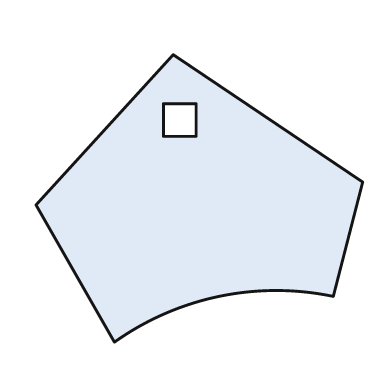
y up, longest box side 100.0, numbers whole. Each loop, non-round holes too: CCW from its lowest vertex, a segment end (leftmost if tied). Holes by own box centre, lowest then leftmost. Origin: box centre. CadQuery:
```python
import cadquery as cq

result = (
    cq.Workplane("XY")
    .moveTo(-26.0, -44.0)
    .threePointArc((6.0, -30.0), (41.0, -30.0))
    .lineTo(50.0, 5.0)
    .lineTo(-8.0, 44.0)
    .lineTo(-50.0, -2.0)
    .close()
    .moveTo(-11.0, 19.0)
    .lineTo(-1.0, 19.0)
    .lineTo(-1.0, 29.0)
    .lineTo(-11.0, 29.0)
    .close()
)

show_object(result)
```